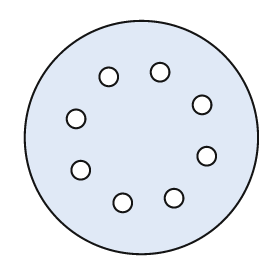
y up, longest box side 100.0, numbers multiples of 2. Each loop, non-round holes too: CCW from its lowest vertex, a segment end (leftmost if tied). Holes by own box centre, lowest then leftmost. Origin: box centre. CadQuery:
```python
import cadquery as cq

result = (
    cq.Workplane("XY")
    .moveTo(0.0, 0.0)
    .circle(50.0)
    .moveTo(-8.0, -28.0)
    .circle(4.0)
    .moveTo(14.0, -26.0)
    .circle(4.0)
    .moveTo(-26.0, -14.0)
    .circle(4.0)
    .moveTo(28.0, -8.0)
    .circle(4.0)
    .moveTo(-28.0, 8.0)
    .circle(4.0)
    .moveTo(26.0, 14.0)
    .circle(4.0)
    .moveTo(-14.0, 26.0)
    .circle(4.0)
    .moveTo(8.0, 28.0)
    .circle(4.0)
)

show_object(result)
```